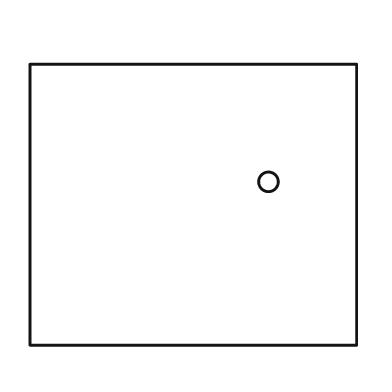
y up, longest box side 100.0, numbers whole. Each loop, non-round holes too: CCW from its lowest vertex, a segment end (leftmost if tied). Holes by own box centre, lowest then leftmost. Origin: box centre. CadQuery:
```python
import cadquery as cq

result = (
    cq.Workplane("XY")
    .moveTo(-50.0, -43.0)
    .lineTo(50.0, -43.0)
    .lineTo(50.0, 43.0)
    .lineTo(-50.0, 43.0)
    .close()
    .moveTo(23.0, 7.0)
    .circle(3.0)
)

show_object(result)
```